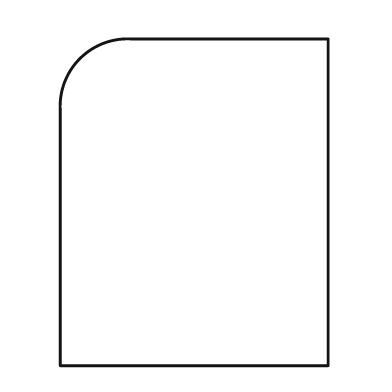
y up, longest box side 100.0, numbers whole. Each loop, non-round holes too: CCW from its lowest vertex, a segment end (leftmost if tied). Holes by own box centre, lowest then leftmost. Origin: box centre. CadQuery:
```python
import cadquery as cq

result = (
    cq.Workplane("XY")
    .moveTo(-41.0, -50.0)
    .lineTo(41.0, -50.0)
    .lineTo(41.0, 50.0)
    .lineTo(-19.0, 50.0)
    .threePointArc((-35.0, 44.0), (-41.0, 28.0))
    .close()
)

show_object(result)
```